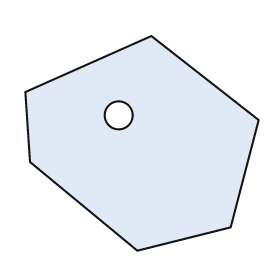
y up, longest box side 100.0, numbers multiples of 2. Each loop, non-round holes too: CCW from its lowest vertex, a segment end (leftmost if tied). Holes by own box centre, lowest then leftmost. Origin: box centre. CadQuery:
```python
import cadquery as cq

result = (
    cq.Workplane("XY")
    .moveTo(-2.0, -46.0)
    .lineTo(38.0, -36.0)
    .lineTo(50.0, 10.0)
    .lineTo(4.0, 46.0)
    .lineTo(-50.0, 22.0)
    .lineTo(-48.0, -8.0)
    .close()
    .moveTo(-10.0, 12.0)
    .circle(6.0)
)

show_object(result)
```